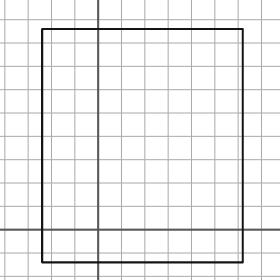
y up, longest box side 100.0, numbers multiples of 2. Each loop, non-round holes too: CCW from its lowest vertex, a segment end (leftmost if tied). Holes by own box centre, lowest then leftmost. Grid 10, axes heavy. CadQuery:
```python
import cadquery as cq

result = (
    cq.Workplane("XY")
    .moveTo(-24.0, -14.0)
    .lineTo(62.0, -14.0)
    .lineTo(62.0, 86.0)
    .lineTo(-24.0, 86.0)
    .close()
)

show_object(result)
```